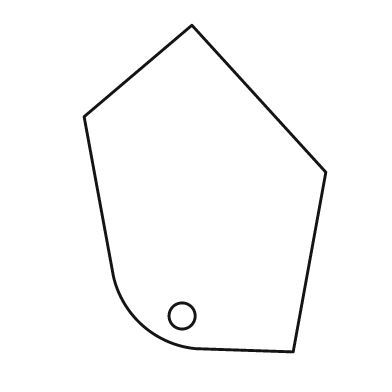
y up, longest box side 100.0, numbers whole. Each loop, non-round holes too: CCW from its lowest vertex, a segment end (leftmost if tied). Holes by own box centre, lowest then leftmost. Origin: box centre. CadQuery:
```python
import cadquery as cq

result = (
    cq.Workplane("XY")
    .moveTo(27.0, -50.0)
    .lineTo(37.0, 5.0)
    .lineTo(-4.0, 50.0)
    .lineTo(-37.0, 22.0)
    .lineTo(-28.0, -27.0)
    .threePointArc((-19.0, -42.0), (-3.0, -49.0))
    .close()
    .moveTo(-7.0, -39.0)
    .circle(4.0)
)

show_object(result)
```